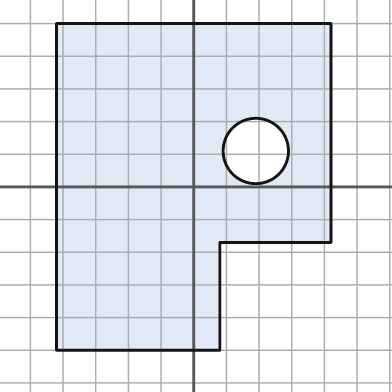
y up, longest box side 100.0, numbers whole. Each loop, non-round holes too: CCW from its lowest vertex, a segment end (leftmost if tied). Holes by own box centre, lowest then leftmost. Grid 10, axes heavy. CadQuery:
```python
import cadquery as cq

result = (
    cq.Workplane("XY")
    .moveTo(-42.0, -50.0)
    .lineTo(8.0, -50.0)
    .lineTo(8.0, -17.0)
    .lineTo(42.0, -17.0)
    .lineTo(42.0, 50.0)
    .lineTo(-42.0, 50.0)
    .close()
    .moveTo(19.0, 11.0)
    .circle(10.0)
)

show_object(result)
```